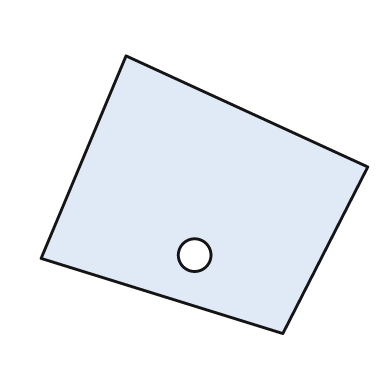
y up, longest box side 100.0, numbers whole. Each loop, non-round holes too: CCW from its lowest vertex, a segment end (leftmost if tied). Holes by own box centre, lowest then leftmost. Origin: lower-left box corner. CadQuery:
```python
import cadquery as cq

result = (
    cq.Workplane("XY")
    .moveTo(74.0, 0.0)
    .lineTo(100.0, 51.0)
    .lineTo(26.0, 85.0)
    .lineTo(0.0, 23.0)
    .close()
    .moveTo(47.0, 24.0)
    .circle(5.0)
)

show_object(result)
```